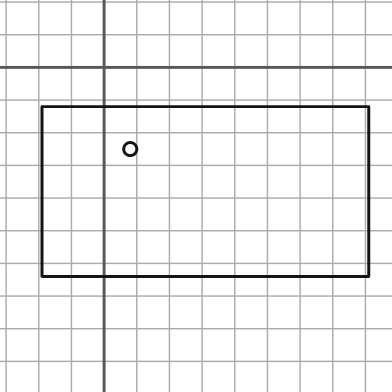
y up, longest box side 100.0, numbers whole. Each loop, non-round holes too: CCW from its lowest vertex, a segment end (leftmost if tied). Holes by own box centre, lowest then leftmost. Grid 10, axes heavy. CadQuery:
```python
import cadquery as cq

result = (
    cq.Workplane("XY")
    .moveTo(-19.0, -64.0)
    .lineTo(81.0, -64.0)
    .lineTo(81.0, -12.0)
    .lineTo(-19.0, -12.0)
    .close()
    .moveTo(8.0, -25.0)
    .circle(2.0)
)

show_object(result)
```